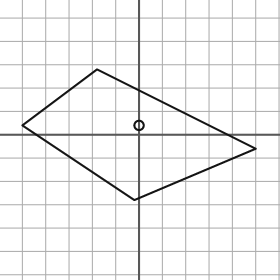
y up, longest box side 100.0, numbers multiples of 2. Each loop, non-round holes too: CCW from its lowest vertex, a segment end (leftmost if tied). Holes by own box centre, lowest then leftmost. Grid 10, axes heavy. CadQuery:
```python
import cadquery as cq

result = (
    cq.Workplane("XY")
    .moveTo(-2.0, -28.0)
    .lineTo(50.0, -6.0)
    .lineTo(-18.0, 28.0)
    .lineTo(-50.0, 4.0)
    .close()
    .moveTo(0.0, 4.0)
    .circle(2.0)
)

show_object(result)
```